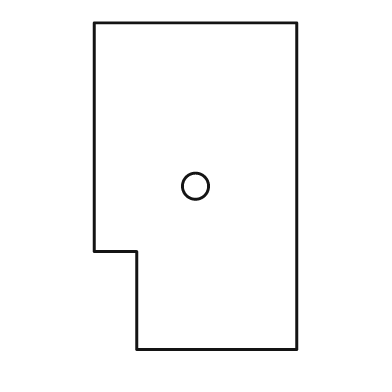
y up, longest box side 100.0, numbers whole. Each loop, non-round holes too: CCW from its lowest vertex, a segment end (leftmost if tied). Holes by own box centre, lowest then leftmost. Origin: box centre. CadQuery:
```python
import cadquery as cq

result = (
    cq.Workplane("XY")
    .moveTo(-18.0, -50.0)
    .lineTo(31.0, -50.0)
    .lineTo(31.0, 50.0)
    .lineTo(-31.0, 50.0)
    .lineTo(-31.0, -20.0)
    .lineTo(-18.0, -20.0)
    .close()
    .moveTo(0.0, 0.0)
    .circle(4.0)
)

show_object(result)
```